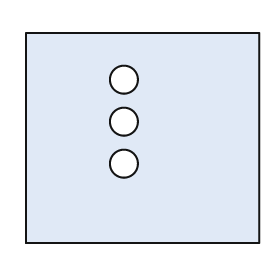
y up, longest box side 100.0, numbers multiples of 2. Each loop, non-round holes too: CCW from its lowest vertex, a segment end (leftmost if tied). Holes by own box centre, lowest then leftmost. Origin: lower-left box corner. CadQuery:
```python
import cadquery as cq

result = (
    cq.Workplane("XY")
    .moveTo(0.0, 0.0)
    .lineTo(100.0, 0.0)
    .lineTo(100.0, 90.0)
    .lineTo(0.0, 90.0)
    .close()
    .moveTo(42.0, 34.0)
    .circle(6.0)
    .moveTo(42.0, 52.0)
    .circle(6.0)
    .moveTo(42.0, 70.0)
    .circle(6.0)
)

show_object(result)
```